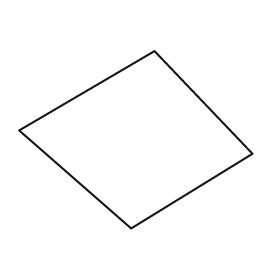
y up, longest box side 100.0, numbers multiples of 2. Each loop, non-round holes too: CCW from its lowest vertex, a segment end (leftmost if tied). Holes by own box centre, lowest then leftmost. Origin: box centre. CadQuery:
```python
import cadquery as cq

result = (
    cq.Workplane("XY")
    .moveTo(-2.0, -38.0)
    .lineTo(50.0, -6.0)
    .lineTo(8.0, 38.0)
    .lineTo(-50.0, 4.0)
    .close()
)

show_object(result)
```